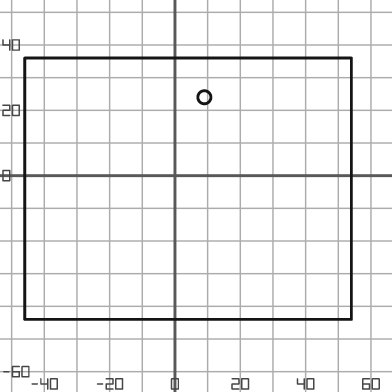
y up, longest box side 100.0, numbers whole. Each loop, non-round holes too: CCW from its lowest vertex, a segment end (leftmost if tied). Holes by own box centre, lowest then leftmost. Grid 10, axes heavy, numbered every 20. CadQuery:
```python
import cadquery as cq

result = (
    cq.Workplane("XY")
    .moveTo(-46.0, -44.0)
    .lineTo(54.0, -44.0)
    .lineTo(54.0, 36.0)
    .lineTo(-46.0, 36.0)
    .close()
    .moveTo(9.0, 24.0)
    .circle(2.0)
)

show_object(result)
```